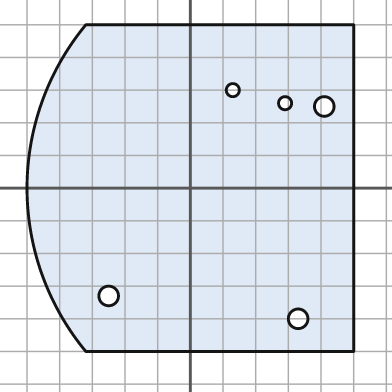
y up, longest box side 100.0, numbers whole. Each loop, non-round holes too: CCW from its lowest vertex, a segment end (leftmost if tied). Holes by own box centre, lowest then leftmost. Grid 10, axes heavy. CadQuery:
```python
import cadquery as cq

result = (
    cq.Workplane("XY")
    .moveTo(-32.0, -50.0)
    .lineTo(50.0, -50.0)
    .lineTo(50.0, 50.0)
    .lineTo(-32.0, 50.0)
    .threePointArc((-50.0, 0.0), (-32.0, -50.0))
    .close()
    .moveTo(33.0, -40.0)
    .circle(3.0)
    .moveTo(-25.0, -33.0)
    .circle(3.0)
    .moveTo(41.0, 25.0)
    .circle(3.0)
    .moveTo(29.0, 26.0)
    .circle(2.0)
    .moveTo(13.0, 30.0)
    .circle(2.0)
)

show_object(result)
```